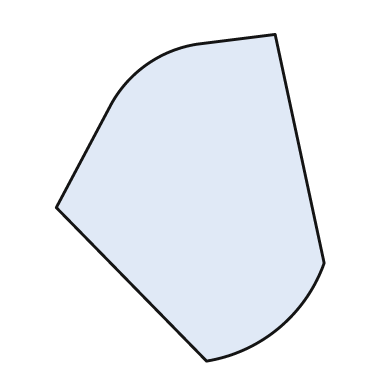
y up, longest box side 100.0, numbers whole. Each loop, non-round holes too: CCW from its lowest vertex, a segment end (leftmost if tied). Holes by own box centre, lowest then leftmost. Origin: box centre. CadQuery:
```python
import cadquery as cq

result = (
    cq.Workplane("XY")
    .moveTo(5.0, -50.0)
    .threePointArc((27.0, -40.0), (41.0, -20.0))
    .lineTo(26.0, 50.0)
    .lineTo(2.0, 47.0)
    .threePointArc((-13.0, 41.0), (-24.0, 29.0))
    .lineTo(-41.0, -3.0)
    .close()
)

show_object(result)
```